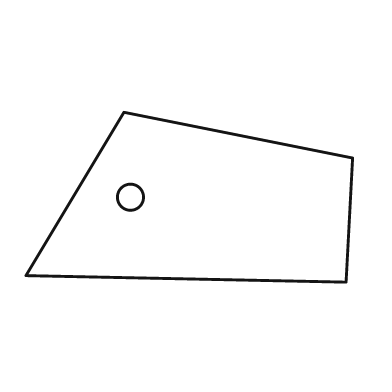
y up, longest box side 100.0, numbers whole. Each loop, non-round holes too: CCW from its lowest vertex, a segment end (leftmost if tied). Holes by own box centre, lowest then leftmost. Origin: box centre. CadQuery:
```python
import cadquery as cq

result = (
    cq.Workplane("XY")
    .moveTo(48.0, -26.0)
    .lineTo(50.0, 12.0)
    .lineTo(-20.0, 26.0)
    .lineTo(-50.0, -24.0)
    .close()
    .moveTo(-18.0, 0.0)
    .circle(4.0)
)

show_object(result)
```